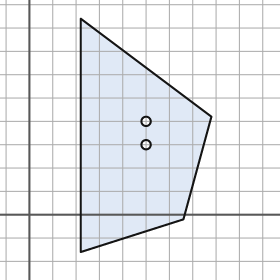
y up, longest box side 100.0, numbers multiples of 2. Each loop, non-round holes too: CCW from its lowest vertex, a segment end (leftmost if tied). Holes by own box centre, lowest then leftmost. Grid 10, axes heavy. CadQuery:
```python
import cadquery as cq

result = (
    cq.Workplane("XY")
    .moveTo(22.0, -16.0)
    .lineTo(66.0, -2.0)
    .lineTo(78.0, 42.0)
    .lineTo(22.0, 84.0)
    .close()
    .moveTo(50.0, 30.0)
    .circle(2.0)
    .moveTo(50.0, 40.0)
    .circle(2.0)
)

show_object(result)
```